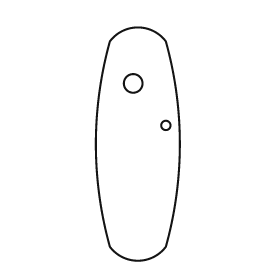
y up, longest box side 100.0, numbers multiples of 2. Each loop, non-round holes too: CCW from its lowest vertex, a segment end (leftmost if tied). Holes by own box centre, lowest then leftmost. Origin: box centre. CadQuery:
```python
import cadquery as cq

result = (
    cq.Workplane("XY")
    .moveTo(-12.0, -44.0)
    .threePointArc((0.0, -50.0), (12.0, -44.0))
    .threePointArc((18.0, 0.0), (12.0, 44.0))
    .threePointArc((0.0, 50.0), (-12.0, 44.0))
    .threePointArc((-18.0, 0.0), (-12.0, -44.0))
    .close()
    .moveTo(12.0, 8.0)
    .circle(2.0)
    .moveTo(-2.0, 26.0)
    .circle(4.0)
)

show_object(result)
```